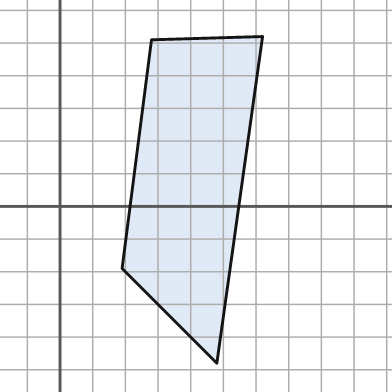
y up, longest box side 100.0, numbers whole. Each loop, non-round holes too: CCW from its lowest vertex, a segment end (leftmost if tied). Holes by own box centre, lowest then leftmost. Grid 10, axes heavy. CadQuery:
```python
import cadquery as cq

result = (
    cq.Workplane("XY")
    .moveTo(48.0, -48.0)
    .lineTo(62.0, 52.0)
    .lineTo(28.0, 51.0)
    .lineTo(19.0, -19.0)
    .close()
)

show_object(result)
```